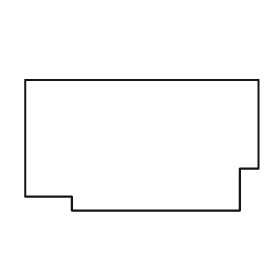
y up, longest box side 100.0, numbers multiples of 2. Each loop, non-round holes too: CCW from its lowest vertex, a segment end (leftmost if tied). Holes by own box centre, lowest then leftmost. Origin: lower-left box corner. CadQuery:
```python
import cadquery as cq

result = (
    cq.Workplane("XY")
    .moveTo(20.0, 0.0)
    .lineTo(92.0, 0.0)
    .lineTo(92.0, 18.0)
    .lineTo(100.0, 18.0)
    .lineTo(100.0, 56.0)
    .lineTo(0.0, 56.0)
    .lineTo(0.0, 6.0)
    .lineTo(20.0, 6.0)
    .close()
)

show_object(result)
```